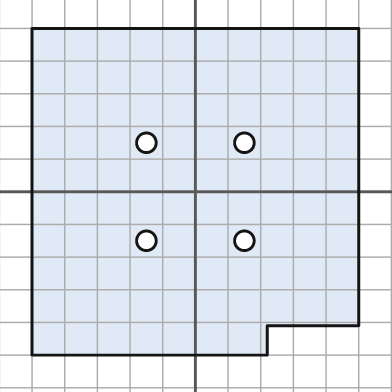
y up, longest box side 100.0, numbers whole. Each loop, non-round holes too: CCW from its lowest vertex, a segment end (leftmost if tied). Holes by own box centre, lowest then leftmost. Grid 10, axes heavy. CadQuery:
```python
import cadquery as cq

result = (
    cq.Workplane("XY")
    .moveTo(-50.0, -50.0)
    .lineTo(22.0, -50.0)
    .lineTo(22.0, -41.0)
    .lineTo(50.0, -41.0)
    .lineTo(50.0, 50.0)
    .lineTo(-50.0, 50.0)
    .close()
    .moveTo(-15.0, -15.0)
    .circle(3.0)
    .moveTo(15.0, -15.0)
    .circle(3.0)
    .moveTo(-15.0, 15.0)
    .circle(3.0)
    .moveTo(15.0, 15.0)
    .circle(3.0)
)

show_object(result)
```